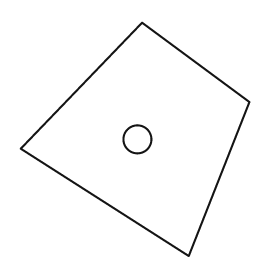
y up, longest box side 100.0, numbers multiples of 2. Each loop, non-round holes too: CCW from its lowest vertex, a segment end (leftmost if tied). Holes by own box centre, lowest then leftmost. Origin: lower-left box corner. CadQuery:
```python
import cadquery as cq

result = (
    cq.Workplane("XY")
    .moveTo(72.0, 0.0)
    .lineTo(98.0, 66.0)
    .lineTo(52.0, 100.0)
    .lineTo(0.0, 46.0)
    .close()
    .moveTo(50.0, 50.0)
    .circle(6.0)
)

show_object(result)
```